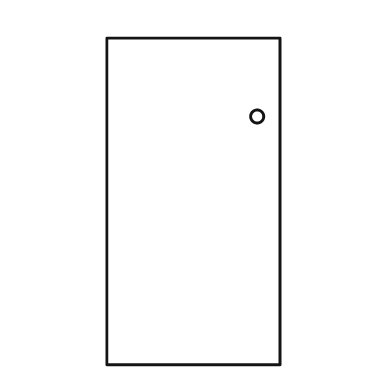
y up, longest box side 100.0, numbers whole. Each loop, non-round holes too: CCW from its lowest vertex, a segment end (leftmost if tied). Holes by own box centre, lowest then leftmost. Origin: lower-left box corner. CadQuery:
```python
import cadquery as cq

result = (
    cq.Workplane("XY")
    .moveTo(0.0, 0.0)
    .lineTo(53.0, 0.0)
    .lineTo(53.0, 100.0)
    .lineTo(0.0, 100.0)
    .close()
    .moveTo(46.0, 76.0)
    .circle(2.0)
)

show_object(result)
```